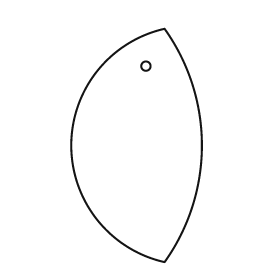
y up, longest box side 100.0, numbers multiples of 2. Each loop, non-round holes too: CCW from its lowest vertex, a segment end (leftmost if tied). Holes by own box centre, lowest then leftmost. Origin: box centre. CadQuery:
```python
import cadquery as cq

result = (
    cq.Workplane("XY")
    .moveTo(12.0, -50.0)
    .threePointArc((28.0, 0.0), (12.0, 50.0))
    .threePointArc((-28.0, 0.0), (12.0, -50.0))
    .close()
    .moveTo(4.0, 34.0)
    .circle(2.0)
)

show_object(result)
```